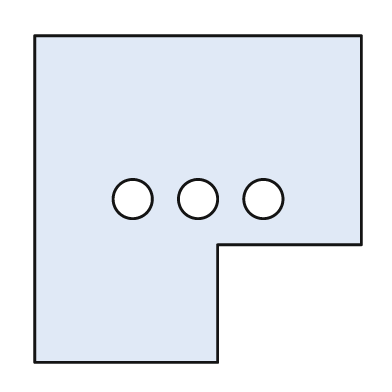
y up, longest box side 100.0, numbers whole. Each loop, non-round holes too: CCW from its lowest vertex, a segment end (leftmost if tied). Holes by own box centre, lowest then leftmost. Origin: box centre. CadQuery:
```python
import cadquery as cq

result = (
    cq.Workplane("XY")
    .moveTo(-50.0, -50.0)
    .lineTo(6.0, -50.0)
    .lineTo(6.0, -14.0)
    .lineTo(50.0, -14.0)
    .lineTo(50.0, 50.0)
    .lineTo(-50.0, 50.0)
    .close()
    .moveTo(-20.0, 0.0)
    .circle(6.0)
    .moveTo(0.0, 0.0)
    .circle(6.0)
    .moveTo(20.0, 0.0)
    .circle(6.0)
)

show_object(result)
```